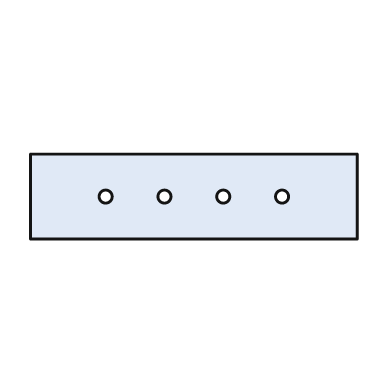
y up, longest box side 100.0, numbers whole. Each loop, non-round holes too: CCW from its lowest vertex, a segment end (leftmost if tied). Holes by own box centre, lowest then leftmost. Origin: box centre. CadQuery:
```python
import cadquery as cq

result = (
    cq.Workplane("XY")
    .moveTo(-50.0, -13.0)
    .lineTo(50.0, -13.0)
    .lineTo(50.0, 13.0)
    .lineTo(-50.0, 13.0)
    .close()
    .moveTo(-27.0, 0.0)
    .circle(2.0)
    .moveTo(-9.0, 0.0)
    .circle(2.0)
    .moveTo(9.0, 0.0)
    .circle(2.0)
    .moveTo(27.0, 0.0)
    .circle(2.0)
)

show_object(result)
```